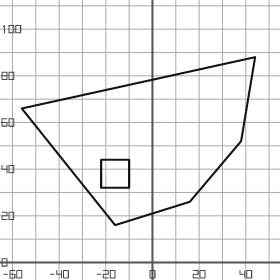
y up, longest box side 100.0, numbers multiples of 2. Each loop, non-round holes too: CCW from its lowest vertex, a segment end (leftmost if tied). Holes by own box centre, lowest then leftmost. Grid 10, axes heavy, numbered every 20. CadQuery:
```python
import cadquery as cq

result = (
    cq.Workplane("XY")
    .moveTo(-16.0, 16.0)
    .lineTo(16.0, 26.0)
    .lineTo(38.0, 52.0)
    .lineTo(44.0, 88.0)
    .lineTo(-56.0, 66.0)
    .close()
    .moveTo(-22.0, 32.0)
    .lineTo(-10.0, 32.0)
    .lineTo(-10.0, 44.0)
    .lineTo(-22.0, 44.0)
    .close()
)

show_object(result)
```